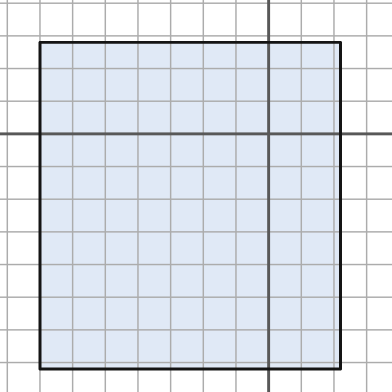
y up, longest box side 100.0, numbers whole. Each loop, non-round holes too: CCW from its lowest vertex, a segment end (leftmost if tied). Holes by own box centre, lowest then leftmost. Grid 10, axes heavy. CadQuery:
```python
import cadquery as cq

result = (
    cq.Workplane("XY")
    .moveTo(-70.0, -72.0)
    .lineTo(22.0, -72.0)
    .lineTo(22.0, 28.0)
    .lineTo(-70.0, 28.0)
    .close()
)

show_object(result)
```